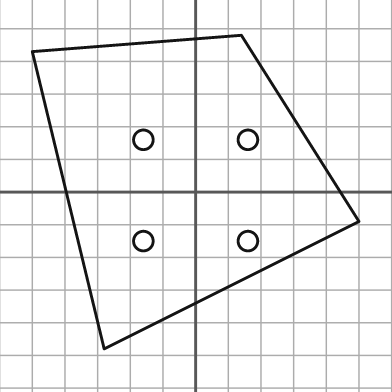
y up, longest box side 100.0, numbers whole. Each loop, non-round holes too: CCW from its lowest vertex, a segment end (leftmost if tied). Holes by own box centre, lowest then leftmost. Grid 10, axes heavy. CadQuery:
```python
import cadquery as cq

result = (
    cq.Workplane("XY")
    .moveTo(-28.0, -48.0)
    .lineTo(50.0, -9.0)
    .lineTo(14.0, 48.0)
    .lineTo(-50.0, 43.0)
    .close()
    .moveTo(-16.0, -15.0)
    .circle(3.0)
    .moveTo(16.0, -15.0)
    .circle(3.0)
    .moveTo(-16.0, 16.0)
    .circle(3.0)
    .moveTo(16.0, 16.0)
    .circle(3.0)
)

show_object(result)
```